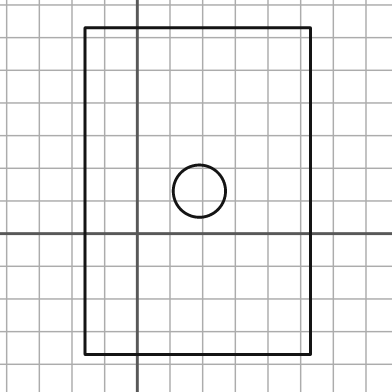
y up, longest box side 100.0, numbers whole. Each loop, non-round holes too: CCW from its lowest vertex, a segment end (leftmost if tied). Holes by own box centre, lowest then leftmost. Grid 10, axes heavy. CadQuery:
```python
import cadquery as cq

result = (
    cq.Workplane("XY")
    .moveTo(-16.0, -37.0)
    .lineTo(53.0, -37.0)
    .lineTo(53.0, 63.0)
    .lineTo(-16.0, 63.0)
    .close()
    .moveTo(19.0, 13.0)
    .circle(8.0)
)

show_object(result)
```